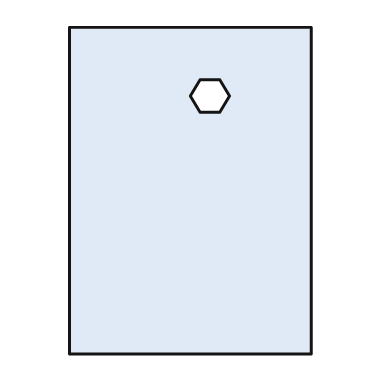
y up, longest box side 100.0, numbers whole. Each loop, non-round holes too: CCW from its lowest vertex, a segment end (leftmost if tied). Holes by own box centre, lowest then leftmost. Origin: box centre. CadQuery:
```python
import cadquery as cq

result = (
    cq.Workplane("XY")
    .moveTo(-37.0, -50.0)
    .lineTo(37.0, -50.0)
    .lineTo(37.0, 50.0)
    .lineTo(-37.0, 50.0)
    .close()
    .moveTo(3.0, 24.0)
    .lineTo(9.0, 24.0)
    .lineTo(12.0, 29.0)
    .lineTo(9.0, 34.0)
    .lineTo(3.0, 34.0)
    .lineTo(0.0, 29.0)
    .close()
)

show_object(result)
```